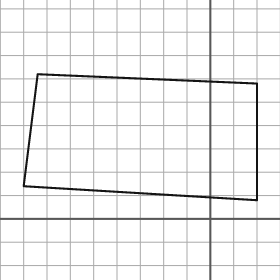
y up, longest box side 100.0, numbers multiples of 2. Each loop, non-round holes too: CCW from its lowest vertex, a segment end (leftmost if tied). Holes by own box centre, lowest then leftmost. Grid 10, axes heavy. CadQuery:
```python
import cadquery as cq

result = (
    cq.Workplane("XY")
    .moveTo(20.0, 8.0)
    .lineTo(20.0, 58.0)
    .lineTo(-74.0, 62.0)
    .lineTo(-80.0, 14.0)
    .close()
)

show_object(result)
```